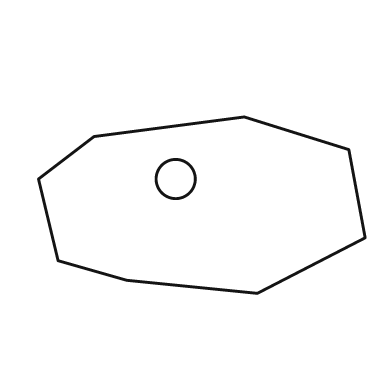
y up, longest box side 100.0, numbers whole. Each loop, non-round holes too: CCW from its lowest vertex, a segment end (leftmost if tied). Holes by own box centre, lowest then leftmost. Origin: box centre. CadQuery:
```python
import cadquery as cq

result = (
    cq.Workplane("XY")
    .moveTo(17.0, -27.0)
    .lineTo(50.0, -10.0)
    .lineTo(45.0, 17.0)
    .lineTo(13.0, 27.0)
    .lineTo(-33.0, 21.0)
    .lineTo(-50.0, 8.0)
    .lineTo(-44.0, -17.0)
    .lineTo(-23.0, -23.0)
    .close()
    .moveTo(-8.0, 8.0)
    .circle(6.0)
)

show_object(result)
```